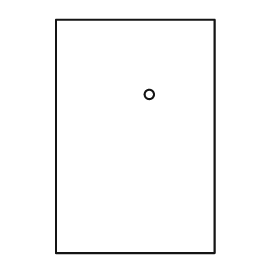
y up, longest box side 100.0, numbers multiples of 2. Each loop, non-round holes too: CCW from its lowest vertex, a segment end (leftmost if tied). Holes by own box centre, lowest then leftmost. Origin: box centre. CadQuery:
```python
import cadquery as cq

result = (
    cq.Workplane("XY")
    .moveTo(-34.0, -50.0)
    .lineTo(34.0, -50.0)
    .lineTo(34.0, 50.0)
    .lineTo(-34.0, 50.0)
    .close()
    .moveTo(6.0, 18.0)
    .circle(2.0)
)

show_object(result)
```